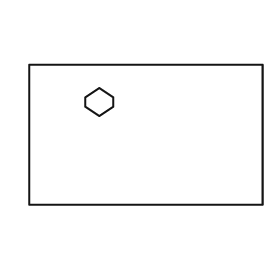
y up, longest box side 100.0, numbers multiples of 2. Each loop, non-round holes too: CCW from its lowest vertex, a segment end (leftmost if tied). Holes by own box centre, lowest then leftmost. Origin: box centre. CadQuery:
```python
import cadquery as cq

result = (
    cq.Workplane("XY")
    .moveTo(-50.0, -30.0)
    .lineTo(50.0, -30.0)
    .lineTo(50.0, 30.0)
    .lineTo(-50.0, 30.0)
    .close()
    .moveTo(-20.0, 8.0)
    .lineTo(-14.0, 12.0)
    .lineTo(-14.0, 16.0)
    .lineTo(-20.0, 20.0)
    .lineTo(-26.0, 16.0)
    .lineTo(-26.0, 12.0)
    .close()
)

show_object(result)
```